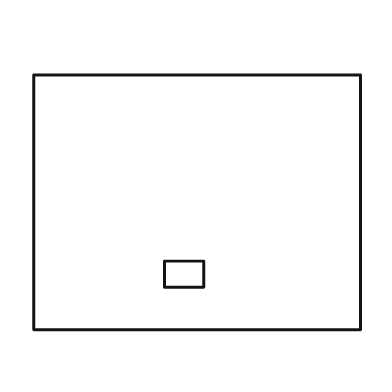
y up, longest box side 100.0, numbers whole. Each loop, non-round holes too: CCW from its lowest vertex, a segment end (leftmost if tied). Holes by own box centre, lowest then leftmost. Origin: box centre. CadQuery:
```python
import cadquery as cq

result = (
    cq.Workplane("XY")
    .moveTo(-50.0, -39.0)
    .lineTo(50.0, -39.0)
    .lineTo(50.0, 39.0)
    .lineTo(-50.0, 39.0)
    .close()
    .moveTo(-10.0, -26.0)
    .lineTo(2.0, -26.0)
    .lineTo(2.0, -18.0)
    .lineTo(-10.0, -18.0)
    .close()
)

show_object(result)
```